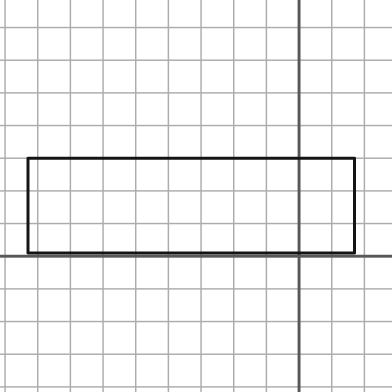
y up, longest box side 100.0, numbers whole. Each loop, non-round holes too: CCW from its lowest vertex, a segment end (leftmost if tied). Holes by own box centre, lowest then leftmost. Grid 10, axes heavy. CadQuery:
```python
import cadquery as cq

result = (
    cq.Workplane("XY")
    .moveTo(-83.0, 1.0)
    .lineTo(17.0, 1.0)
    .lineTo(17.0, 30.0)
    .lineTo(-83.0, 30.0)
    .close()
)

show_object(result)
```